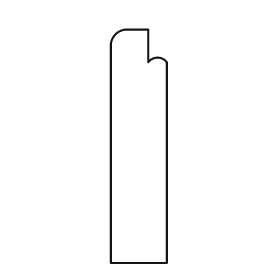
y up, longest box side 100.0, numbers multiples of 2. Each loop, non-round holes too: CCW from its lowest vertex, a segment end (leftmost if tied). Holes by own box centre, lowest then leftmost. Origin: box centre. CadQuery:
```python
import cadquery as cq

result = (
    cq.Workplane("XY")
    .moveTo(-12.0, -50.0)
    .lineTo(12.0, -50.0)
    .lineTo(12.0, 36.0)
    .threePointArc((8.0, 38.0), (4.0, 36.0))
    .lineTo(4.0, 50.0)
    .lineTo(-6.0, 50.0)
    .threePointArc((-10.0, 48.0), (-12.0, 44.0))
    .close()
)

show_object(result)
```